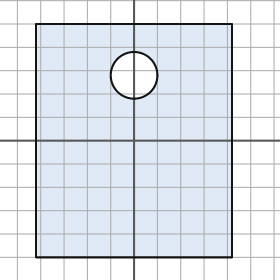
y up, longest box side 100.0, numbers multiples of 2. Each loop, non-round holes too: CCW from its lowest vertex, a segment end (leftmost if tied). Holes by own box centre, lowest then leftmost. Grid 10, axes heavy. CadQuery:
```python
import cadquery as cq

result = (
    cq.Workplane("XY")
    .moveTo(-42.0, -50.0)
    .lineTo(42.0, -50.0)
    .lineTo(42.0, 50.0)
    .lineTo(-42.0, 50.0)
    .close()
    .moveTo(0.0, 28.0)
    .circle(10.0)
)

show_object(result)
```